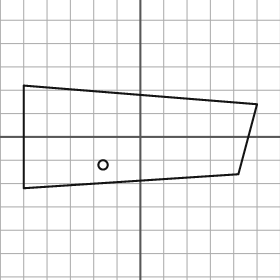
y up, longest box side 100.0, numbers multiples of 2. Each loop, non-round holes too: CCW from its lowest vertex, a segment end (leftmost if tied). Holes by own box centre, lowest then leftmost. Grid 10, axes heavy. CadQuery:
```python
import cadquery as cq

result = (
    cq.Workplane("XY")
    .moveTo(-50.0, -22.0)
    .lineTo(42.0, -16.0)
    .lineTo(50.0, 14.0)
    .lineTo(-50.0, 22.0)
    .close()
    .moveTo(-16.0, -12.0)
    .circle(2.0)
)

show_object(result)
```